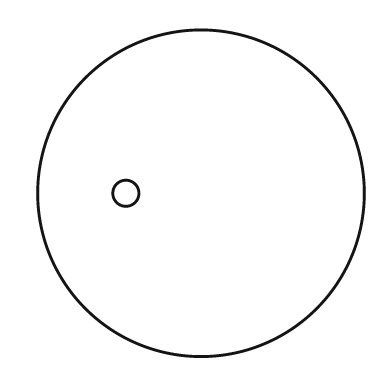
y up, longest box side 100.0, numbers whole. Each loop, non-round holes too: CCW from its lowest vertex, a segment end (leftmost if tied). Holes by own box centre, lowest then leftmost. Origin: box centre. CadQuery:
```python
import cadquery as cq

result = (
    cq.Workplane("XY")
    .moveTo(0.0, 0.0)
    .circle(50.0)
    .moveTo(-23.0, 0.0)
    .circle(4.0)
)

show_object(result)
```